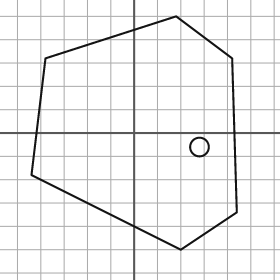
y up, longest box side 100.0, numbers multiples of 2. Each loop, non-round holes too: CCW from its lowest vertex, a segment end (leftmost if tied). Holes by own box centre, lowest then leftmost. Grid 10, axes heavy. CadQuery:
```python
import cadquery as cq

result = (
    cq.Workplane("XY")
    .moveTo(20.0, -50.0)
    .lineTo(44.0, -34.0)
    .lineTo(42.0, 32.0)
    .lineTo(18.0, 50.0)
    .lineTo(-38.0, 32.0)
    .lineTo(-44.0, -18.0)
    .close()
    .moveTo(28.0, -6.0)
    .circle(4.0)
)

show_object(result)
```